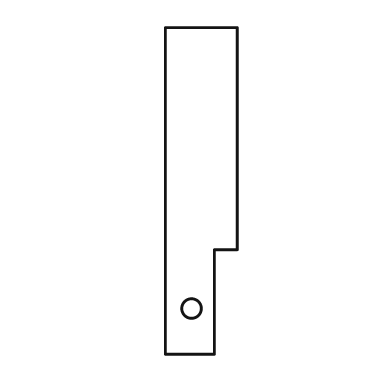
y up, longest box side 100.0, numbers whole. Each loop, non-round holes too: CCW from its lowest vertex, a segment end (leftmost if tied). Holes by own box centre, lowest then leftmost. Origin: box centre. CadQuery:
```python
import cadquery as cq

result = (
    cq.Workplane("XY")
    .moveTo(-11.0, -50.0)
    .lineTo(4.0, -50.0)
    .lineTo(4.0, -18.0)
    .lineTo(11.0, -18.0)
    .lineTo(11.0, 50.0)
    .lineTo(-11.0, 50.0)
    .close()
    .moveTo(-3.0, -36.0)
    .circle(3.0)
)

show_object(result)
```